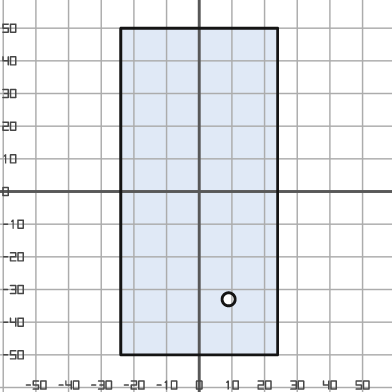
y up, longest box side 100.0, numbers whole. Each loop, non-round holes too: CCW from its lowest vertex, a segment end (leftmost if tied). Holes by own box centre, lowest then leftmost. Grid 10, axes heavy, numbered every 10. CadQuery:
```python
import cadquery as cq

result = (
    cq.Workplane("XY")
    .moveTo(-24.0, -50.0)
    .lineTo(24.0, -50.0)
    .lineTo(24.0, 50.0)
    .lineTo(-24.0, 50.0)
    .close()
    .moveTo(9.0, -33.0)
    .circle(2.0)
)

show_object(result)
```